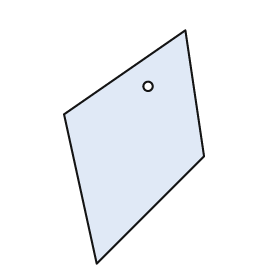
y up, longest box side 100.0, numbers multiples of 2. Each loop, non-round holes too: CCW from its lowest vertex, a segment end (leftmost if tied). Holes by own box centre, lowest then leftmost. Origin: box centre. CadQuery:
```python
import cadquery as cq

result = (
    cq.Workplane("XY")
    .moveTo(-16.0, -50.0)
    .lineTo(30.0, -4.0)
    .lineTo(22.0, 50.0)
    .lineTo(-30.0, 14.0)
    .close()
    .moveTo(6.0, 26.0)
    .circle(2.0)
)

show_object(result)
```